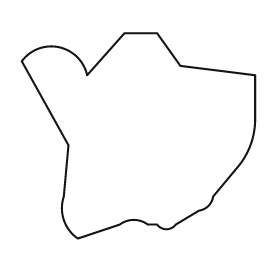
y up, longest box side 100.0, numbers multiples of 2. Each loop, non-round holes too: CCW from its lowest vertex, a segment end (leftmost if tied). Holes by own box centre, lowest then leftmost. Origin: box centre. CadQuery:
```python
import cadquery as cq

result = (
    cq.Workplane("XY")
    .moveTo(-26.0, -44.0)
    .lineTo(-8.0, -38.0)
    .threePointArc((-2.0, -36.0), (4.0, -38.0))
    .lineTo(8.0, -38.0)
    .threePointArc((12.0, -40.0), (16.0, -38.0))
    .lineTo(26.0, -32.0)
    .threePointArc((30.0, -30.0), (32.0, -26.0))
    .lineTo(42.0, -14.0)
    .threePointArc((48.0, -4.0), (50.0, 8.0))
    .lineTo(50.0, 26.0)
    .lineTo(18.0, 30.0)
    .lineTo(8.0, 44.0)
    .lineTo(-6.0, 44.0)
    .lineTo(-22.0, 26.0)
    .threePointArc((-34.0, 38.0), (-50.0, 32.0))
    .lineTo(-30.0, -4.0)
    .lineTo(-32.0, -26.0)
    .threePointArc((-32.0, -36.0), (-26.0, -44.0))
    .close()
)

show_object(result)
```